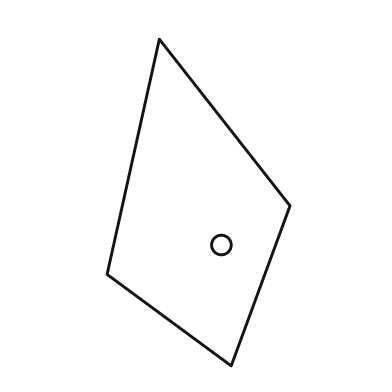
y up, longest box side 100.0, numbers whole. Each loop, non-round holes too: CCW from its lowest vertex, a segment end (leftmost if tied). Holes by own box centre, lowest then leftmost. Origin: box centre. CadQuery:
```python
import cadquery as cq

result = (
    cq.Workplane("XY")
    .moveTo(10.0, -50.0)
    .lineTo(28.0, -1.0)
    .lineTo(-12.0, 50.0)
    .lineTo(-28.0, -22.0)
    .close()
    .moveTo(7.0, -13.0)
    .circle(3.0)
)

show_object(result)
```